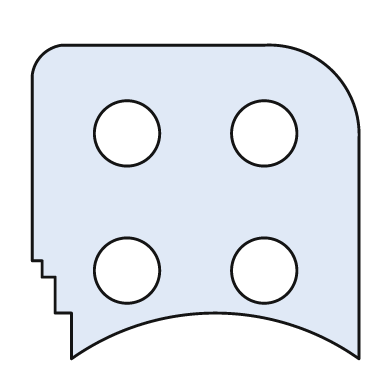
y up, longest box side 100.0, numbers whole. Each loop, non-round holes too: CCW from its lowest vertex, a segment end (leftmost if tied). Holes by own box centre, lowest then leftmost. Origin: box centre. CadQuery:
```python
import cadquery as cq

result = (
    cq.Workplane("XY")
    .moveTo(-38.0, -48.0)
    .threePointArc((6.0, -34.0), (50.0, -48.0))
    .lineTo(50.0, 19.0)
    .threePointArc((42.0, 40.0), (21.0, 48.0))
    .lineTo(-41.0, 48.0)
    .threePointArc((-47.0, 45.0), (-50.0, 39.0))
    .lineTo(-50.0, -18.0)
    .lineTo(-47.0, -18.0)
    .lineTo(-47.0, -23.0)
    .lineTo(-43.0, -23.0)
    .lineTo(-43.0, -34.0)
    .lineTo(-38.0, -34.0)
    .close()
    .moveTo(-21.0, -21.0)
    .circle(10.0)
    .moveTo(21.0, -21.0)
    .circle(10.0)
    .moveTo(-21.0, 21.0)
    .circle(10.0)
    .moveTo(21.0, 21.0)
    .circle(10.0)
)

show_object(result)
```